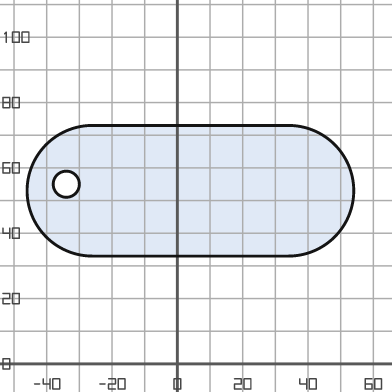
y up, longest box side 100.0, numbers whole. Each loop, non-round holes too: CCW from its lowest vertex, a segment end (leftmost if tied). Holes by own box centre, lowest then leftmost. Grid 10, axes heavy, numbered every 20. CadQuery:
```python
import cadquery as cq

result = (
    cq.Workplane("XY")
    .moveTo(-26.0, 33.0)
    .lineTo(34.0, 33.0)
    .threePointArc((54.0, 53.0), (34.0, 73.0))
    .lineTo(-26.0, 73.0)
    .threePointArc((-46.0, 53.0), (-26.0, 33.0))
    .close()
    .moveTo(-34.0, 55.0)
    .circle(4.0)
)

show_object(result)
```